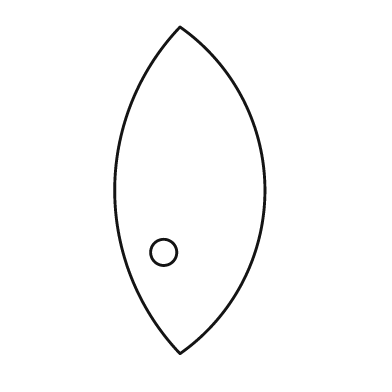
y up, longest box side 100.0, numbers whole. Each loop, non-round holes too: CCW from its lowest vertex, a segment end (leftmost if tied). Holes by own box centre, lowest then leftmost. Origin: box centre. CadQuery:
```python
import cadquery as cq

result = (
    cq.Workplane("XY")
    .moveTo(-3.0, -50.0)
    .threePointArc((23.0, 0.0), (-3.0, 50.0))
    .threePointArc((-23.0, 0.0), (-3.0, -50.0))
    .close()
    .moveTo(-8.0, -19.0)
    .circle(4.0)
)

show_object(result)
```